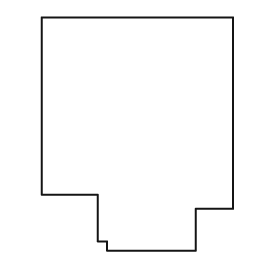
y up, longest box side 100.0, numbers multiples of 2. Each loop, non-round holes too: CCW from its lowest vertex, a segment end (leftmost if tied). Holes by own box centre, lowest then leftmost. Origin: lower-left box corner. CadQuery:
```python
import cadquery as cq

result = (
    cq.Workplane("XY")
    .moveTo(28.0, 0.0)
    .lineTo(66.0, 0.0)
    .lineTo(66.0, 18.0)
    .lineTo(82.0, 18.0)
    .lineTo(82.0, 100.0)
    .lineTo(0.0, 100.0)
    .lineTo(0.0, 24.0)
    .lineTo(24.0, 24.0)
    .lineTo(24.0, 4.0)
    .lineTo(28.0, 4.0)
    .close()
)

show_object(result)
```